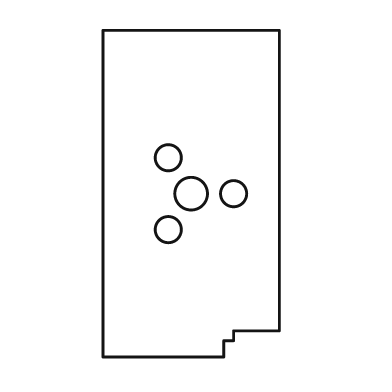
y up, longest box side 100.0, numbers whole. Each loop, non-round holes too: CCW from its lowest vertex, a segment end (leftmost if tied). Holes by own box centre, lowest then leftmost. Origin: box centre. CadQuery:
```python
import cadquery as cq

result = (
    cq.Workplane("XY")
    .moveTo(-27.0, -50.0)
    .lineTo(10.0, -50.0)
    .lineTo(10.0, -45.0)
    .lineTo(13.0, -45.0)
    .lineTo(13.0, -42.0)
    .lineTo(27.0, -42.0)
    .lineTo(27.0, 50.0)
    .lineTo(-27.0, 50.0)
    .close()
    .moveTo(-7.0, -11.0)
    .circle(4.0)
    .moveTo(0.0, 0.0)
    .circle(5.0)
    .moveTo(13.0, 0.0)
    .circle(4.0)
    .moveTo(-7.0, 11.0)
    .circle(4.0)
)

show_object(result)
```